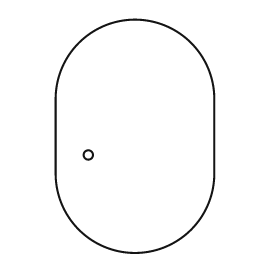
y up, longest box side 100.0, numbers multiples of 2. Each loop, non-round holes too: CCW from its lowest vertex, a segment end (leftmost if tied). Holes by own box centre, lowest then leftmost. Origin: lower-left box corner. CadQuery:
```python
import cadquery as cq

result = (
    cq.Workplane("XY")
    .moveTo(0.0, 34.0)
    .threePointArc((34.0, 0.0), (68.0, 34.0))
    .lineTo(68.0, 66.0)
    .threePointArc((34.0, 100.0), (0.0, 66.0))
    .close()
    .moveTo(14.0, 42.0)
    .circle(2.0)
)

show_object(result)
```